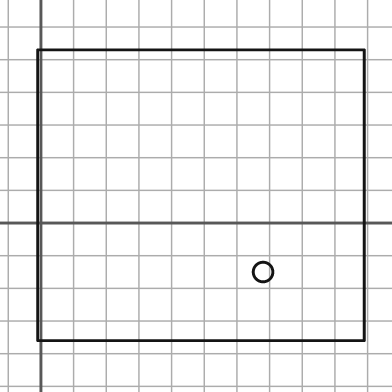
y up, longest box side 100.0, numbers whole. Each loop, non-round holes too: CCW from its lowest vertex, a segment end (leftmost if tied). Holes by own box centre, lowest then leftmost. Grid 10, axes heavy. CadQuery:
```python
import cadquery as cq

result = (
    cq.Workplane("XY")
    .moveTo(-1.0, -36.0)
    .lineTo(99.0, -36.0)
    .lineTo(99.0, 53.0)
    .lineTo(-1.0, 53.0)
    .close()
    .moveTo(68.0, -15.0)
    .circle(3.0)
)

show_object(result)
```